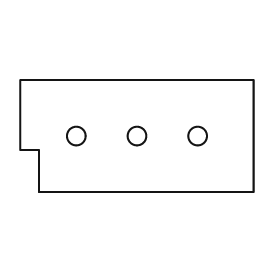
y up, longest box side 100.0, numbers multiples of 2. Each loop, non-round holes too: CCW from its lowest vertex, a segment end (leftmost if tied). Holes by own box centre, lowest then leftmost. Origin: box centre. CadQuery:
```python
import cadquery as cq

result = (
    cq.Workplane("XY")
    .moveTo(-42.0, -24.0)
    .lineTo(50.0, -24.0)
    .lineTo(50.0, 24.0)
    .lineTo(-50.0, 24.0)
    .lineTo(-50.0, -6.0)
    .lineTo(-42.0, -6.0)
    .close()
    .moveTo(-26.0, 0.0)
    .circle(4.0)
    .moveTo(0.0, 0.0)
    .circle(4.0)
    .moveTo(26.0, 0.0)
    .circle(4.0)
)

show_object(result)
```